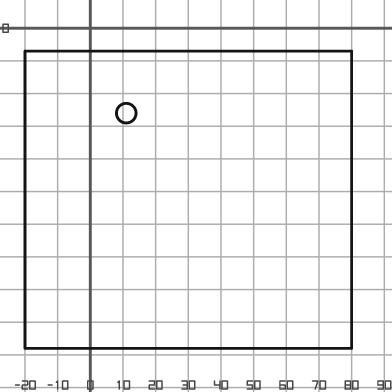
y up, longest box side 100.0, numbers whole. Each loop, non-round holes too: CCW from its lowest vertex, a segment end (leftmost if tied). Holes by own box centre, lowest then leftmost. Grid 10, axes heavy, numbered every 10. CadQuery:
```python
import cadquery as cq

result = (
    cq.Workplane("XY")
    .moveTo(-20.0, -98.0)
    .lineTo(80.0, -98.0)
    .lineTo(80.0, -7.0)
    .lineTo(-20.0, -7.0)
    .close()
    .moveTo(11.0, -26.0)
    .circle(3.0)
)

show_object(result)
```